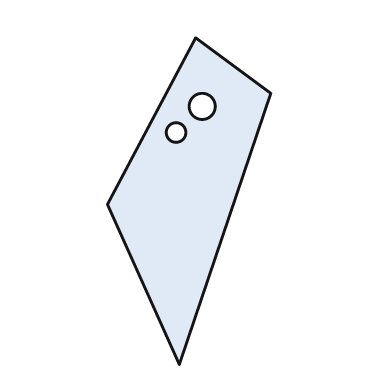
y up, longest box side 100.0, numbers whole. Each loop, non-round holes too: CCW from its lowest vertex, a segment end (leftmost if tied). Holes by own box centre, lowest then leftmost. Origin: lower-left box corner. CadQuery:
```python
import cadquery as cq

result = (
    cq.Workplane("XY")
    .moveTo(22.0, 0.0)
    .lineTo(50.0, 83.0)
    .lineTo(27.0, 100.0)
    .lineTo(0.0, 49.0)
    .close()
    .moveTo(21.0, 71.0)
    .circle(3.0)
    .moveTo(29.0, 79.0)
    .circle(4.0)
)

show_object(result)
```